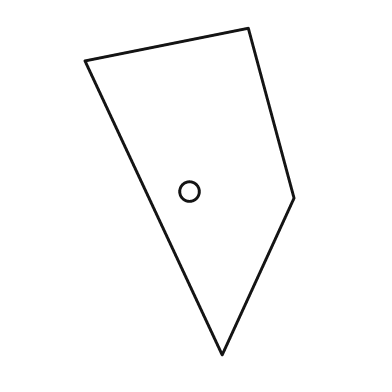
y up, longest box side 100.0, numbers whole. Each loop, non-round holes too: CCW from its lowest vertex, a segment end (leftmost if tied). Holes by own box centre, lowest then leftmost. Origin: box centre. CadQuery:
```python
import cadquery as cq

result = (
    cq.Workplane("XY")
    .moveTo(10.0, -50.0)
    .lineTo(32.0, -2.0)
    .lineTo(18.0, 50.0)
    .lineTo(-32.0, 40.0)
    .close()
    .moveTo(0.0, 0.0)
    .circle(3.0)
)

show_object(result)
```